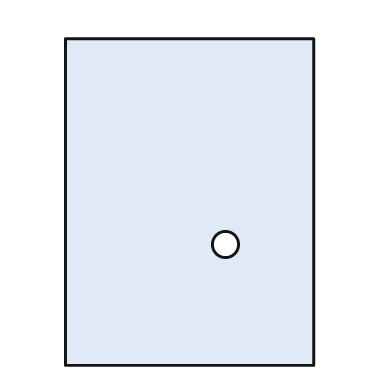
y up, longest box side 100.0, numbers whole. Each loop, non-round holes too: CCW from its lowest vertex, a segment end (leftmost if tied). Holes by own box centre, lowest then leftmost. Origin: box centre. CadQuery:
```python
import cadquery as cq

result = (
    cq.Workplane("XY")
    .moveTo(-38.0, -50.0)
    .lineTo(38.0, -50.0)
    .lineTo(38.0, 50.0)
    .lineTo(-38.0, 50.0)
    .close()
    .moveTo(11.0, -13.0)
    .circle(4.0)
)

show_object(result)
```